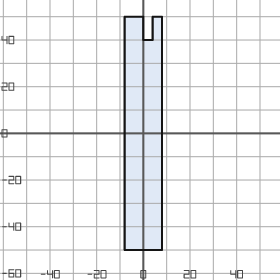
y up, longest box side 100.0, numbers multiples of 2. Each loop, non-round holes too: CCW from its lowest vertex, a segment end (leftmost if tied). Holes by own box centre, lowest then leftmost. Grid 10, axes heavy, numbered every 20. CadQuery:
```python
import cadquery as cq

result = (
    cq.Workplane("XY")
    .moveTo(-8.0, -50.0)
    .lineTo(8.0, -50.0)
    .lineTo(8.0, 50.0)
    .lineTo(4.0, 50.0)
    .lineTo(4.0, 40.0)
    .lineTo(0.0, 40.0)
    .lineTo(0.0, 50.0)
    .lineTo(-8.0, 50.0)
    .close()
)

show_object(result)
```